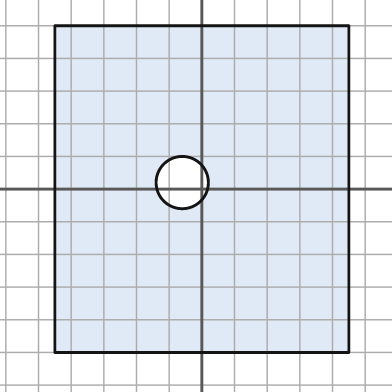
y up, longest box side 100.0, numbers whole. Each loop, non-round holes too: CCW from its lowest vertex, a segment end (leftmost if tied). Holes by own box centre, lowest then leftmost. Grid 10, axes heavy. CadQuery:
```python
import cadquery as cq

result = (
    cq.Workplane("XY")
    .moveTo(-45.0, -50.0)
    .lineTo(45.0, -50.0)
    .lineTo(45.0, 50.0)
    .lineTo(-45.0, 50.0)
    .close()
    .moveTo(-6.0, 2.0)
    .circle(8.0)
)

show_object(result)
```